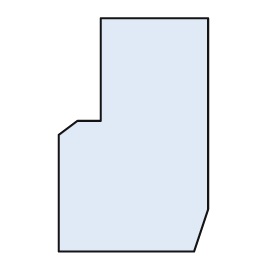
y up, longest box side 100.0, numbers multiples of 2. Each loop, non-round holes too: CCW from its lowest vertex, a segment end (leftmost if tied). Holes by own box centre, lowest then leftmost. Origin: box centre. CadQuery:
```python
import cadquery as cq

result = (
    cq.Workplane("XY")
    .moveTo(-32.0, -50.0)
    .lineTo(26.0, -50.0)
    .lineTo(32.0, -32.0)
    .lineTo(32.0, 50.0)
    .lineTo(-14.0, 50.0)
    .lineTo(-14.0, 6.0)
    .lineTo(-24.0, 6.0)
    .lineTo(-32.0, 0.0)
    .close()
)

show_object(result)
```